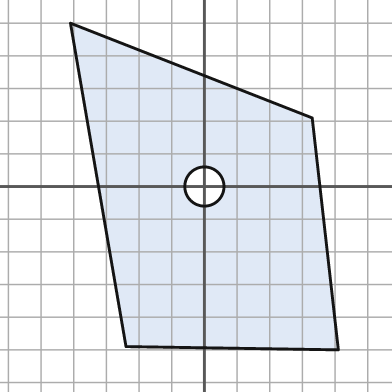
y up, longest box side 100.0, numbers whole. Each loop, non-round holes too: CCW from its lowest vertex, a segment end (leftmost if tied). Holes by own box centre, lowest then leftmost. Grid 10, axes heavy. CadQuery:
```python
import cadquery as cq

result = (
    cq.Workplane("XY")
    .moveTo(41.0, -50.0)
    .lineTo(33.0, 21.0)
    .lineTo(-41.0, 50.0)
    .lineTo(-24.0, -49.0)
    .close()
    .moveTo(0.0, 0.0)
    .circle(6.0)
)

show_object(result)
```